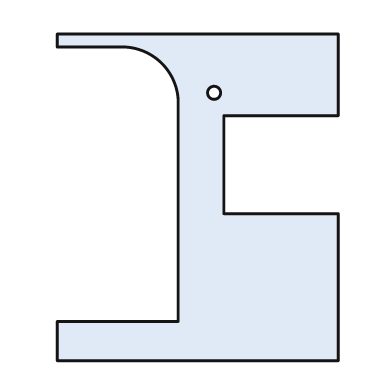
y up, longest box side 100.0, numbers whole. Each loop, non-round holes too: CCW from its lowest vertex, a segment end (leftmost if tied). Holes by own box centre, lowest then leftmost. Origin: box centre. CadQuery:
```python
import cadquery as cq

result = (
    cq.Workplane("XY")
    .moveTo(-43.0, -50.0)
    .lineTo(43.0, -50.0)
    .lineTo(43.0, -5.0)
    .lineTo(8.0, -5.0)
    .lineTo(8.0, 25.0)
    .lineTo(43.0, 25.0)
    .lineTo(43.0, 50.0)
    .lineTo(-43.0, 50.0)
    .lineTo(-43.0, 46.0)
    .lineTo(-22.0, 46.0)
    .threePointArc((-11.0, 41.0), (-6.0, 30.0))
    .lineTo(-6.0, -38.0)
    .lineTo(-43.0, -38.0)
    .close()
    .moveTo(5.0, 32.0)
    .circle(2.0)
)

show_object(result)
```